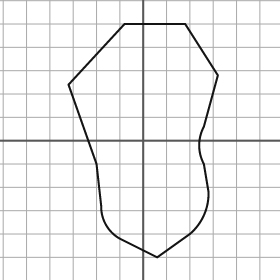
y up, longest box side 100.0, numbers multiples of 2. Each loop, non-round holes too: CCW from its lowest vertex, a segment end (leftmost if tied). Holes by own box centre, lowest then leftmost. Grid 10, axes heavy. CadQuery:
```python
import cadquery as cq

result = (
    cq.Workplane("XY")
    .moveTo(6.0, -50.0)
    .lineTo(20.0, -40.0)
    .threePointArc((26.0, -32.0), (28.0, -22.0))
    .lineTo(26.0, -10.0)
    .threePointArc((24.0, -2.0), (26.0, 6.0))
    .lineTo(32.0, 28.0)
    .lineTo(18.0, 50.0)
    .lineTo(-8.0, 50.0)
    .lineTo(-32.0, 24.0)
    .lineTo(-20.0, -10.0)
    .lineTo(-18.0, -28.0)
    .threePointArc((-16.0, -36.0), (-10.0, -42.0))
    .close()
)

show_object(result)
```